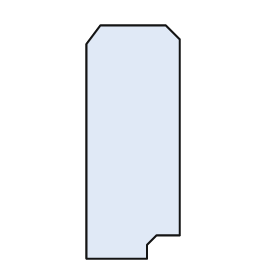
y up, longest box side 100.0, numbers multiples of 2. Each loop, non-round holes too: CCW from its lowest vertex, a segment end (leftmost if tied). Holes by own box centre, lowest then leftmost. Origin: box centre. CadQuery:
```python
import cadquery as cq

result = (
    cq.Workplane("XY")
    .moveTo(-20.0, -50.0)
    .lineTo(6.0, -50.0)
    .lineTo(6.0, -44.0)
    .lineTo(10.0, -40.0)
    .lineTo(20.0, -40.0)
    .lineTo(20.0, 44.0)
    .lineTo(14.0, 50.0)
    .lineTo(-14.0, 50.0)
    .lineTo(-20.0, 42.0)
    .close()
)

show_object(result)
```